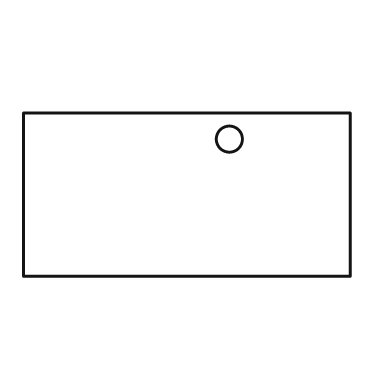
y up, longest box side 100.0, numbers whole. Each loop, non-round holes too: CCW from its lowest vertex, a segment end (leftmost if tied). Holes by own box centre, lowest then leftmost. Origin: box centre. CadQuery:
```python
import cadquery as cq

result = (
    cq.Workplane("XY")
    .moveTo(-50.0, -25.0)
    .lineTo(50.0, -25.0)
    .lineTo(50.0, 25.0)
    .lineTo(-50.0, 25.0)
    .close()
    .moveTo(13.0, 17.0)
    .circle(4.0)
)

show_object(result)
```